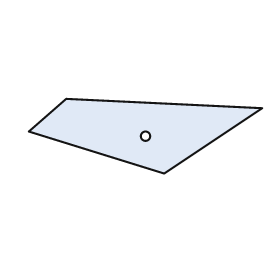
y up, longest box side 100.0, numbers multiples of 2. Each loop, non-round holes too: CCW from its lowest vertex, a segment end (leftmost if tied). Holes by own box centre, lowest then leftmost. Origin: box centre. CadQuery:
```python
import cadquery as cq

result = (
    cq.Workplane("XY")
    .moveTo(8.0, -16.0)
    .lineTo(50.0, 12.0)
    .lineTo(-34.0, 16.0)
    .lineTo(-50.0, 2.0)
    .close()
    .moveTo(0.0, 0.0)
    .circle(2.0)
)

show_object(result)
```